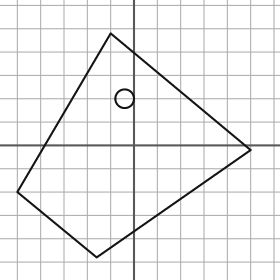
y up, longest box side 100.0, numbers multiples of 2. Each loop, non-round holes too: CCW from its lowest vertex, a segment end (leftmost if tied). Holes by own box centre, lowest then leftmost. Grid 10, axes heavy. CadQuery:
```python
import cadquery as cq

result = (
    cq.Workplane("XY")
    .moveTo(-16.0, -48.0)
    .lineTo(50.0, -2.0)
    .lineTo(-10.0, 48.0)
    .lineTo(-50.0, -20.0)
    .close()
    .moveTo(-4.0, 20.0)
    .circle(4.0)
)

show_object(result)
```